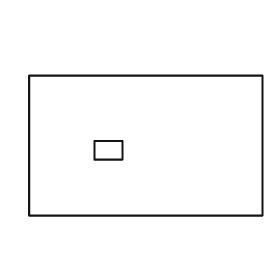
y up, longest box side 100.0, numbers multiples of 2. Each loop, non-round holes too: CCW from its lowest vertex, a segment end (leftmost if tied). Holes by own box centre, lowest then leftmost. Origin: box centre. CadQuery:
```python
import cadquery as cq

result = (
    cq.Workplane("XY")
    .moveTo(-50.0, -30.0)
    .lineTo(50.0, -30.0)
    .lineTo(50.0, 30.0)
    .lineTo(-50.0, 30.0)
    .close()
    .moveTo(-22.0, -6.0)
    .lineTo(-10.0, -6.0)
    .lineTo(-10.0, 2.0)
    .lineTo(-22.0, 2.0)
    .close()
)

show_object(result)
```